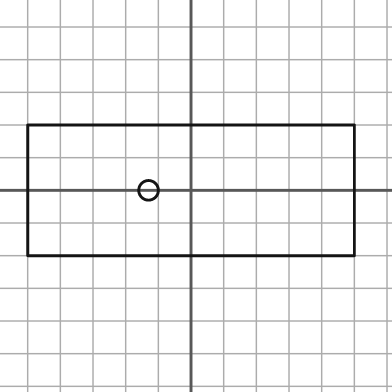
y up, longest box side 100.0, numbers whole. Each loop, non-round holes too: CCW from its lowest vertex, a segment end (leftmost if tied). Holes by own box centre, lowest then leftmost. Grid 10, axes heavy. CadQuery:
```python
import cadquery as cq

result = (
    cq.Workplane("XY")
    .moveTo(-50.0, -20.0)
    .lineTo(50.0, -20.0)
    .lineTo(50.0, 20.0)
    .lineTo(-50.0, 20.0)
    .close()
    .moveTo(-13.0, 0.0)
    .circle(3.0)
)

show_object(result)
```